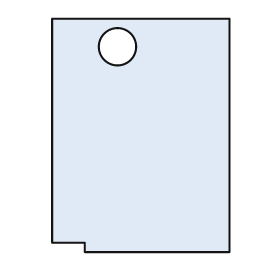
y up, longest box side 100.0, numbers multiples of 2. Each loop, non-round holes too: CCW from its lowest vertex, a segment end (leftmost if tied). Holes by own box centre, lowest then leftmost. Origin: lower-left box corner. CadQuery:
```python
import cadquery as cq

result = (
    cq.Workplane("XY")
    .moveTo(14.0, 0.0)
    .lineTo(76.0, 0.0)
    .lineTo(76.0, 100.0)
    .lineTo(0.0, 100.0)
    .lineTo(0.0, 4.0)
    .lineTo(14.0, 4.0)
    .close()
    .moveTo(28.0, 88.0)
    .circle(8.0)
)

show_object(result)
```